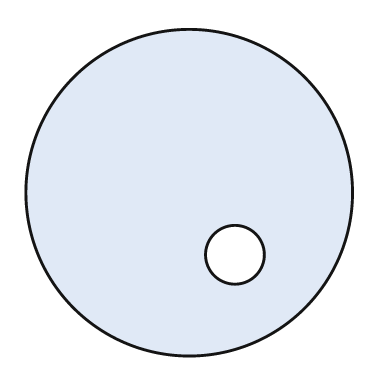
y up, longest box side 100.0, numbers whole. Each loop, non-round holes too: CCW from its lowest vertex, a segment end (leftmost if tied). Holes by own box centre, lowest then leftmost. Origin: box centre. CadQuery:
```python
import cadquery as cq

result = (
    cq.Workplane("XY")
    .moveTo(0.0, 0.0)
    .circle(50.0)
    .moveTo(14.0, -19.0)
    .circle(9.0)
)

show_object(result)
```